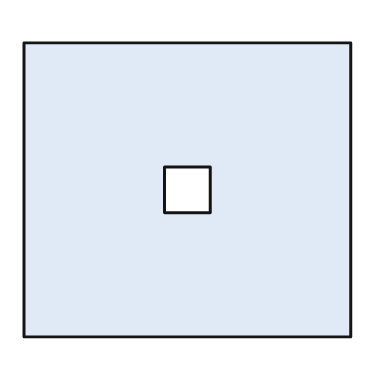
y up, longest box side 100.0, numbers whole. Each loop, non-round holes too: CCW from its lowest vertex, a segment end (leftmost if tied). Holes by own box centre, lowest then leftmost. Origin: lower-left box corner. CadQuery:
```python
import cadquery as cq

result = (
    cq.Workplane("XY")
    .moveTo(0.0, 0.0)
    .lineTo(100.0, 0.0)
    .lineTo(100.0, 90.0)
    .lineTo(0.0, 90.0)
    .close()
    .moveTo(43.0, 38.0)
    .lineTo(57.0, 38.0)
    .lineTo(57.0, 52.0)
    .lineTo(43.0, 52.0)
    .close()
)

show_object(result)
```